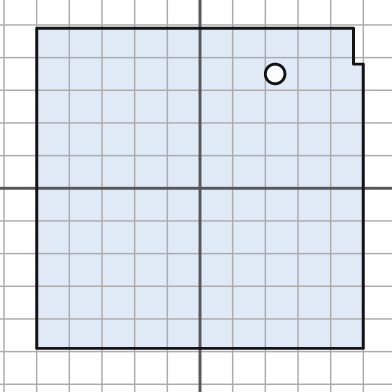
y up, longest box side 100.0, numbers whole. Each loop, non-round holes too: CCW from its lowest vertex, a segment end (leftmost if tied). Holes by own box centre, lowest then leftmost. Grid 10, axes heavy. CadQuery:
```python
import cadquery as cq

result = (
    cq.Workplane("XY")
    .moveTo(-50.0, -49.0)
    .lineTo(50.0, -49.0)
    .lineTo(50.0, 38.0)
    .lineTo(47.0, 38.0)
    .lineTo(47.0, 49.0)
    .lineTo(-50.0, 49.0)
    .close()
    .moveTo(23.0, 35.0)
    .circle(3.0)
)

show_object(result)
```